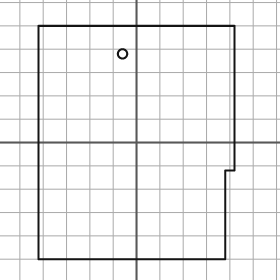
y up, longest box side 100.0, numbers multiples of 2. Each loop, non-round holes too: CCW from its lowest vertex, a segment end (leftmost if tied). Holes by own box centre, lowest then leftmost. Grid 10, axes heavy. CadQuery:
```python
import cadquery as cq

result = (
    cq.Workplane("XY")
    .moveTo(-42.0, -50.0)
    .lineTo(38.0, -50.0)
    .lineTo(38.0, -12.0)
    .lineTo(42.0, -12.0)
    .lineTo(42.0, 50.0)
    .lineTo(-42.0, 50.0)
    .close()
    .moveTo(-6.0, 38.0)
    .circle(2.0)
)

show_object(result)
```